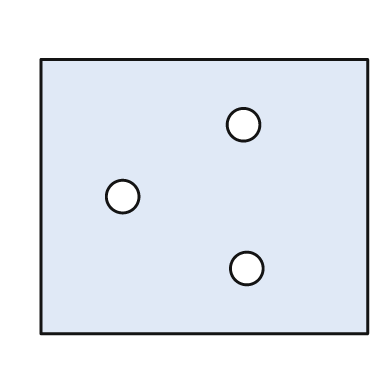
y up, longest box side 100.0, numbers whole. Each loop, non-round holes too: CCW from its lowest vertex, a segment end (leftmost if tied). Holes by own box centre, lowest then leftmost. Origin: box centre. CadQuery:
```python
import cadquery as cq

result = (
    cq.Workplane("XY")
    .moveTo(-50.0, -42.0)
    .lineTo(50.0, -42.0)
    .lineTo(50.0, 42.0)
    .lineTo(-50.0, 42.0)
    .close()
    .moveTo(13.0, -22.0)
    .circle(5.0)
    .moveTo(-25.0, 0.0)
    .circle(5.0)
    .moveTo(12.0, 22.0)
    .circle(5.0)
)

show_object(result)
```